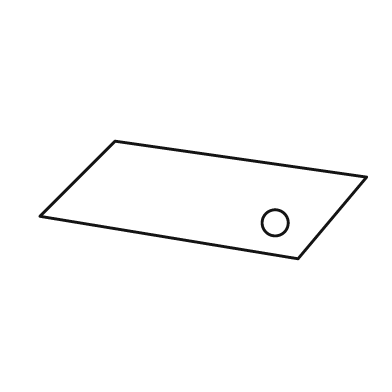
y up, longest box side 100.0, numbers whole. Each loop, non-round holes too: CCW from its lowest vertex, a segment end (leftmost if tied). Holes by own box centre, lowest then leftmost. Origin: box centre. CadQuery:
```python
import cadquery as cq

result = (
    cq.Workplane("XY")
    .moveTo(29.0, -18.0)
    .lineTo(50.0, 7.0)
    .lineTo(-27.0, 18.0)
    .lineTo(-50.0, -5.0)
    .close()
    .moveTo(22.0, -7.0)
    .circle(4.0)
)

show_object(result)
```